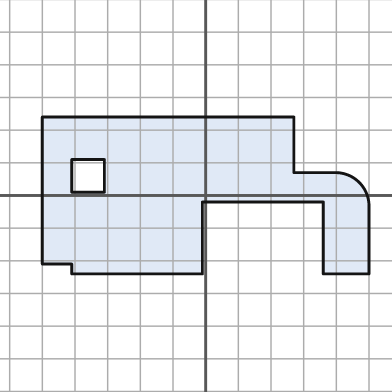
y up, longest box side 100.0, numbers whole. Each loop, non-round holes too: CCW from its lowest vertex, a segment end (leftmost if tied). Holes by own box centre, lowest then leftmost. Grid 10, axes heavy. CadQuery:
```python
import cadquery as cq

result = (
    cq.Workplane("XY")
    .moveTo(-41.0, -24.0)
    .lineTo(-1.0, -24.0)
    .lineTo(-1.0, -2.0)
    .lineTo(36.0, -2.0)
    .lineTo(36.0, -24.0)
    .lineTo(50.0, -24.0)
    .lineTo(50.0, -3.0)
    .threePointArc((47.0, 4.0), (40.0, 7.0))
    .lineTo(27.0, 7.0)
    .lineTo(27.0, 24.0)
    .lineTo(-50.0, 24.0)
    .lineTo(-50.0, -21.0)
    .lineTo(-41.0, -21.0)
    .close()
    .moveTo(-41.0, 1.0)
    .lineTo(-31.0, 1.0)
    .lineTo(-31.0, 11.0)
    .lineTo(-41.0, 11.0)
    .close()
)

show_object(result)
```